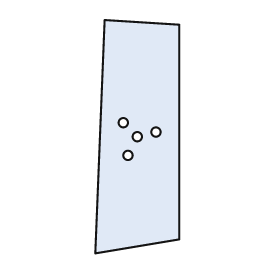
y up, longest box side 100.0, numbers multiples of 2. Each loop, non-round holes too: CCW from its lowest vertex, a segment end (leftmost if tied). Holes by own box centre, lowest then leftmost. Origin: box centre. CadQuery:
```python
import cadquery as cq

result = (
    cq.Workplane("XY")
    .moveTo(-18.0, -50.0)
    .lineTo(18.0, -44.0)
    .lineTo(18.0, 48.0)
    .lineTo(-14.0, 50.0)
    .close()
    .moveTo(-4.0, -8.0)
    .circle(2.0)
    .moveTo(0.0, 0.0)
    .circle(2.0)
    .moveTo(8.0, 2.0)
    .circle(2.0)
    .moveTo(-6.0, 6.0)
    .circle(2.0)
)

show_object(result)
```